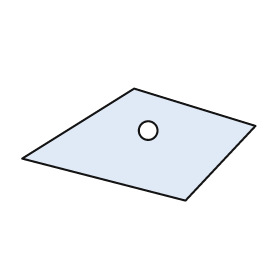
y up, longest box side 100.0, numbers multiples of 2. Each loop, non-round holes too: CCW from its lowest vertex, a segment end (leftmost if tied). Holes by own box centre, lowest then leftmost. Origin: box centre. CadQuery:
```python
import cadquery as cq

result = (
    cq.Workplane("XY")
    .moveTo(20.0, -24.0)
    .lineTo(50.0, 8.0)
    .lineTo(-2.0, 24.0)
    .lineTo(-50.0, -6.0)
    .close()
    .moveTo(4.0, 6.0)
    .circle(4.0)
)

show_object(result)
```